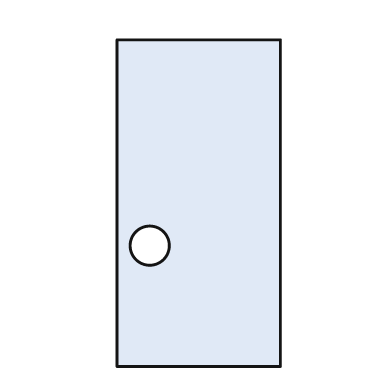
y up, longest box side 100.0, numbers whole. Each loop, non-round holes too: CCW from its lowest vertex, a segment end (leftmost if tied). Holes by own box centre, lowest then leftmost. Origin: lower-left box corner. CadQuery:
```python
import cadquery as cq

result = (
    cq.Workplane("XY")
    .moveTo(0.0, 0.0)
    .lineTo(50.0, 0.0)
    .lineTo(50.0, 100.0)
    .lineTo(0.0, 100.0)
    .close()
    .moveTo(10.0, 37.0)
    .circle(6.0)
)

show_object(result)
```